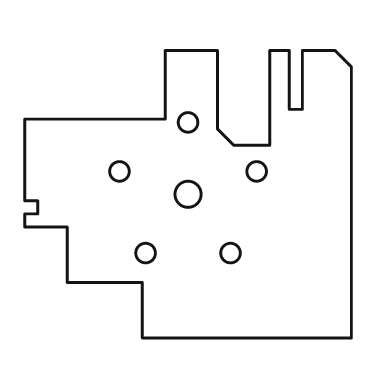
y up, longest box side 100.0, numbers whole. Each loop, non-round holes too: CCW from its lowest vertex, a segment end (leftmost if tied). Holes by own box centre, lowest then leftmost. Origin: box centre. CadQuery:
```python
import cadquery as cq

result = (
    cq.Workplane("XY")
    .moveTo(-14.0, -44.0)
    .lineTo(50.0, -44.0)
    .lineTo(50.0, 39.0)
    .lineTo(45.0, 44.0)
    .lineTo(35.0, 44.0)
    .lineTo(35.0, 26.0)
    .lineTo(31.0, 26.0)
    .lineTo(31.0, 44.0)
    .lineTo(25.0, 44.0)
    .lineTo(25.0, 15.0)
    .lineTo(14.0, 15.0)
    .lineTo(9.0, 20.0)
    .lineTo(9.0, 44.0)
    .lineTo(-7.0, 44.0)
    .lineTo(-7.0, 23.0)
    .lineTo(-50.0, 23.0)
    .lineTo(-50.0, -2.0)
    .lineTo(-46.0, -2.0)
    .lineTo(-46.0, -6.0)
    .lineTo(-50.0, -6.0)
    .lineTo(-50.0, -10.0)
    .lineTo(-37.0, -10.0)
    .lineTo(-37.0, -27.0)
    .lineTo(-14.0, -27.0)
    .close()
    .moveTo(-13.0, -18.0)
    .circle(3.0)
    .moveTo(13.0, -18.0)
    .circle(3.0)
    .moveTo(0.0, 0.0)
    .circle(4.0)
    .moveTo(-21.0, 7.0)
    .circle(3.0)
    .moveTo(21.0, 7.0)
    .circle(3.0)
    .moveTo(0.0, 22.0)
    .circle(3.0)
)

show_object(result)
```